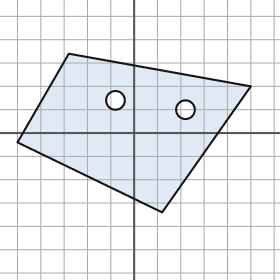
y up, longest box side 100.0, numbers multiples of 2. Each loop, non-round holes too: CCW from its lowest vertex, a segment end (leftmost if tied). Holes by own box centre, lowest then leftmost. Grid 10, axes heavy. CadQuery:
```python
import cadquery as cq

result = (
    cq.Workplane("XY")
    .moveTo(12.0, -34.0)
    .lineTo(50.0, 20.0)
    .lineTo(-28.0, 34.0)
    .lineTo(-50.0, -4.0)
    .close()
    .moveTo(22.0, 10.0)
    .circle(4.0)
    .moveTo(-8.0, 14.0)
    .circle(4.0)
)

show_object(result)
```